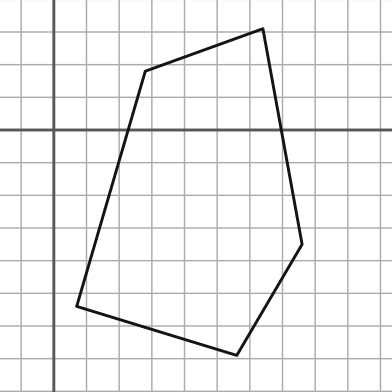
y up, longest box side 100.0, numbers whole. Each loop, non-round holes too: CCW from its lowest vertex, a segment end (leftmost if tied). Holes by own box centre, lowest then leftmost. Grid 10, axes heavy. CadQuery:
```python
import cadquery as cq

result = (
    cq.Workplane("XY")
    .moveTo(56.0, -69.0)
    .lineTo(76.0, -35.0)
    .lineTo(64.0, 31.0)
    .lineTo(28.0, 18.0)
    .lineTo(7.0, -54.0)
    .close()
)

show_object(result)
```